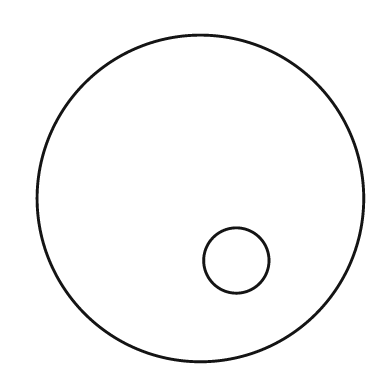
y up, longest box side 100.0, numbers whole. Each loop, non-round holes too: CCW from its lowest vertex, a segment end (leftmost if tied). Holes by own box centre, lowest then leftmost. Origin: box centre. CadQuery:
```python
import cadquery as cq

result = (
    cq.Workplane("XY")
    .moveTo(0.0, 0.0)
    .circle(50.0)
    .moveTo(11.0, -19.0)
    .circle(10.0)
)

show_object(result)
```